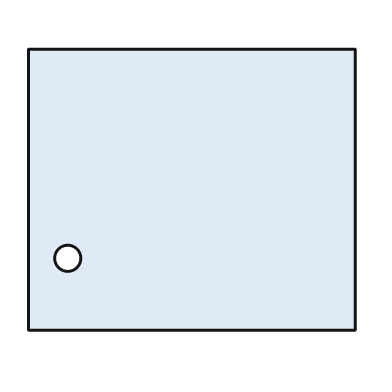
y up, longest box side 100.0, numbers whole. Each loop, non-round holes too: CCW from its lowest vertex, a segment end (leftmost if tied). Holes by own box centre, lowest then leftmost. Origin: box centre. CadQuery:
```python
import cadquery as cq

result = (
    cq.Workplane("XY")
    .moveTo(-50.0, -43.0)
    .lineTo(50.0, -43.0)
    .lineTo(50.0, 43.0)
    .lineTo(-50.0, 43.0)
    .close()
    .moveTo(-38.0, -21.0)
    .circle(4.0)
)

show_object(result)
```